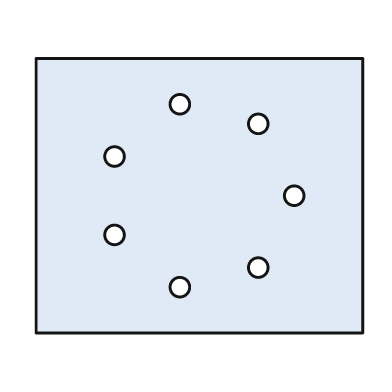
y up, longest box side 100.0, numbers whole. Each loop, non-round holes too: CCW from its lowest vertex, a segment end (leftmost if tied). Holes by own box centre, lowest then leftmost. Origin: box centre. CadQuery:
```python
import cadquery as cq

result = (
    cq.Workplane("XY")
    .moveTo(-50.0, -42.0)
    .lineTo(50.0, -42.0)
    .lineTo(50.0, 42.0)
    .lineTo(-50.0, 42.0)
    .close()
    .moveTo(-6.0, -28.0)
    .circle(3.0)
    .moveTo(18.0, -22.0)
    .circle(3.0)
    .moveTo(-26.0, -12.0)
    .circle(3.0)
    .moveTo(29.0, 0.0)
    .circle(3.0)
    .moveTo(-26.0, 12.0)
    .circle(3.0)
    .moveTo(18.0, 22.0)
    .circle(3.0)
    .moveTo(-6.0, 28.0)
    .circle(3.0)
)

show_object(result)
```